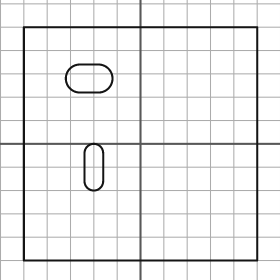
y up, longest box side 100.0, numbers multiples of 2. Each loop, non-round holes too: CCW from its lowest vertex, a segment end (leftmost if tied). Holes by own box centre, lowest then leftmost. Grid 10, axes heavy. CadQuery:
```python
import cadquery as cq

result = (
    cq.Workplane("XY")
    .moveTo(-50.0, -50.0)
    .lineTo(50.0, -50.0)
    .lineTo(50.0, 50.0)
    .lineTo(-50.0, 50.0)
    .close()
    .moveTo(-24.0, -16.0)
    .threePointArc((-20.0, -20.0), (-16.0, -16.0))
    .lineTo(-16.0, -4.0)
    .threePointArc((-20.0, 0.0), (-24.0, -4.0))
    .close()
    .moveTo(-26.0, 22.0)
    .lineTo(-18.0, 22.0)
    .threePointArc((-12.0, 28.0), (-18.0, 34.0))
    .lineTo(-26.0, 34.0)
    .threePointArc((-32.0, 28.0), (-26.0, 22.0))
    .close()
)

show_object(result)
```